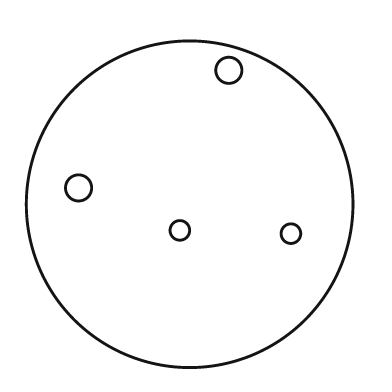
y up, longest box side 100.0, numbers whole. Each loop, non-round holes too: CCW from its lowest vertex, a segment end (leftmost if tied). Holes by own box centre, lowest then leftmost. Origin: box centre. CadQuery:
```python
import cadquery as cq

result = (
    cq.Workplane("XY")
    .moveTo(0.0, 0.0)
    .circle(50.0)
    .moveTo(31.0, -9.0)
    .circle(3.0)
    .moveTo(-3.0, -8.0)
    .circle(3.0)
    .moveTo(-34.0, 5.0)
    .circle(4.0)
    .moveTo(12.0, 41.0)
    .circle(4.0)
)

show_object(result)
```